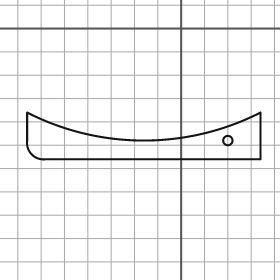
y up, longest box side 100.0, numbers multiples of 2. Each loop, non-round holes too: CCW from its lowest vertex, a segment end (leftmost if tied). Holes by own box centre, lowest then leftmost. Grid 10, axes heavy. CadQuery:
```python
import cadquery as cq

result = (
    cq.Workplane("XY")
    .moveTo(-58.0, -56.0)
    .lineTo(34.0, -56.0)
    .lineTo(34.0, -36.0)
    .threePointArc((-16.0, -48.0), (-66.0, -36.0))
    .lineTo(-66.0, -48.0)
    .threePointArc((-64.0, -54.0), (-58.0, -56.0))
    .close()
    .moveTo(20.0, -48.0)
    .circle(2.0)
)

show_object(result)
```